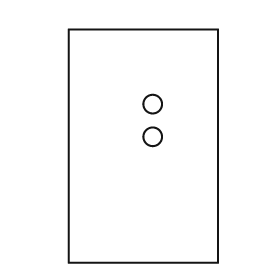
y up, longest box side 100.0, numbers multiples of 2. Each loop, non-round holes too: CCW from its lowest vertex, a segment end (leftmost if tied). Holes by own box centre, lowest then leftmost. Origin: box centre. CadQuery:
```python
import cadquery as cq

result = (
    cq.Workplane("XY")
    .moveTo(-32.0, -50.0)
    .lineTo(32.0, -50.0)
    .lineTo(32.0, 50.0)
    .lineTo(-32.0, 50.0)
    .close()
    .moveTo(4.0, 4.0)
    .circle(4.0)
    .moveTo(4.0, 18.0)
    .circle(4.0)
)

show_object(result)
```